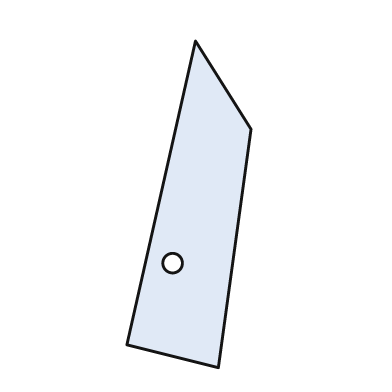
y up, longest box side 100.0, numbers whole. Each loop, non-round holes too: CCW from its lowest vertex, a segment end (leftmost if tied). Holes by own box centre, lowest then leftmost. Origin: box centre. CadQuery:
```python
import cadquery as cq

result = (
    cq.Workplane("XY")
    .moveTo(9.0, -50.0)
    .lineTo(19.0, 23.0)
    .lineTo(2.0, 50.0)
    .lineTo(-19.0, -43.0)
    .close()
    .moveTo(-5.0, -18.0)
    .circle(3.0)
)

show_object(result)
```